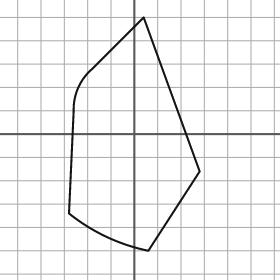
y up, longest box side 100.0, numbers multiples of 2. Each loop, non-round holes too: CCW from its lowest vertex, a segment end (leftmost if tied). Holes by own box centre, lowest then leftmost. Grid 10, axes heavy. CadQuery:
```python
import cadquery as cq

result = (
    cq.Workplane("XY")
    .moveTo(6.0, -50.0)
    .lineTo(28.0, -16.0)
    .lineTo(4.0, 50.0)
    .lineTo(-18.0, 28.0)
    .threePointArc((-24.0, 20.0), (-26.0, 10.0))
    .lineTo(-28.0, -34.0)
    .threePointArc((-12.0, -44.0), (6.0, -50.0))
    .close()
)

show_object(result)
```